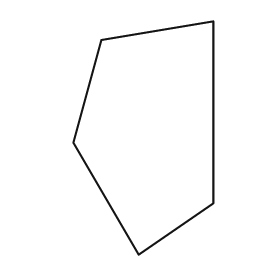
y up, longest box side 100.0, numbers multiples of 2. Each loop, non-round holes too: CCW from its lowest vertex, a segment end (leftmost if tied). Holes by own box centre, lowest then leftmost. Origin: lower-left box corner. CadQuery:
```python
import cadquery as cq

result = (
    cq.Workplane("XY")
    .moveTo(28.0, 0.0)
    .lineTo(60.0, 22.0)
    .lineTo(60.0, 100.0)
    .lineTo(12.0, 92.0)
    .lineTo(0.0, 48.0)
    .close()
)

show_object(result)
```